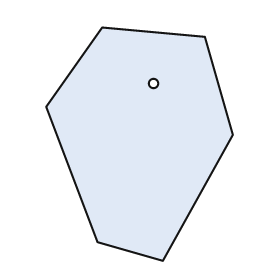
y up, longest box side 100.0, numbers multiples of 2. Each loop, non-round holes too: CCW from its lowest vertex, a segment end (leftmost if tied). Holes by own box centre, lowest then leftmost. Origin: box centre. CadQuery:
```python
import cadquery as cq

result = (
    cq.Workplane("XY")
    .moveTo(10.0, -50.0)
    .lineTo(40.0, 4.0)
    .lineTo(28.0, 46.0)
    .lineTo(-16.0, 50.0)
    .lineTo(-40.0, 16.0)
    .lineTo(-18.0, -42.0)
    .close()
    .moveTo(6.0, 26.0)
    .circle(2.0)
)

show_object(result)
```